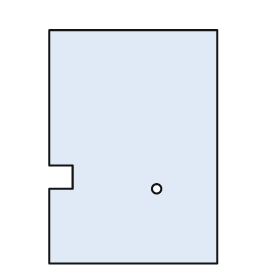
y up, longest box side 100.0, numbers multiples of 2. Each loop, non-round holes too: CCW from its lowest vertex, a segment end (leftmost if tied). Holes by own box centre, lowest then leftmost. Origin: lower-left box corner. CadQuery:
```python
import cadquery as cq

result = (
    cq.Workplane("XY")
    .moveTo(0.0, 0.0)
    .lineTo(72.0, 0.0)
    .lineTo(72.0, 100.0)
    .lineTo(0.0, 100.0)
    .lineTo(0.0, 42.0)
    .lineTo(10.0, 42.0)
    .lineTo(10.0, 32.0)
    .lineTo(0.0, 32.0)
    .close()
    .moveTo(46.0, 32.0)
    .circle(2.0)
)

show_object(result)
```